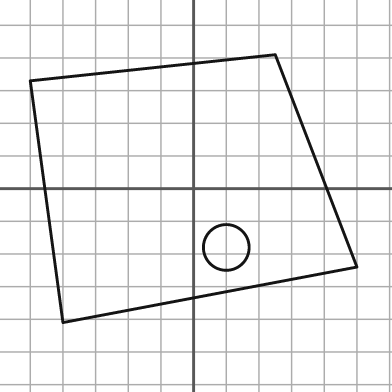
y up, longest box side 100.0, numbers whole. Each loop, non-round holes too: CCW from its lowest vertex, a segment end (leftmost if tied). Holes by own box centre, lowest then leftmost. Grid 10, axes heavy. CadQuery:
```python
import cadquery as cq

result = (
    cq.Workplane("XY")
    .moveTo(-40.0, -41.0)
    .lineTo(50.0, -24.0)
    .lineTo(25.0, 41.0)
    .lineTo(-50.0, 33.0)
    .close()
    .moveTo(10.0, -18.0)
    .circle(7.0)
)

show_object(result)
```